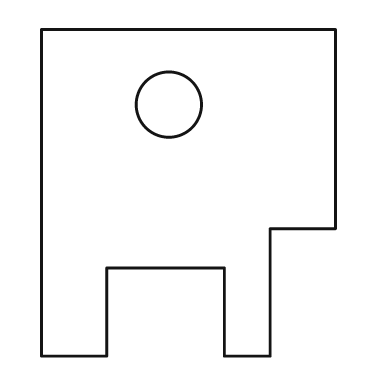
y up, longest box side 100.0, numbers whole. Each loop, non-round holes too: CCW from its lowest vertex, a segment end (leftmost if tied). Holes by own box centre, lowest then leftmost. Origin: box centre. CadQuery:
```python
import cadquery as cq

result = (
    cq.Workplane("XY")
    .moveTo(-45.0, -50.0)
    .lineTo(-25.0, -50.0)
    .lineTo(-25.0, -23.0)
    .lineTo(11.0, -23.0)
    .lineTo(11.0, -50.0)
    .lineTo(25.0, -50.0)
    .lineTo(25.0, -11.0)
    .lineTo(45.0, -11.0)
    .lineTo(45.0, 50.0)
    .lineTo(-45.0, 50.0)
    .close()
    .moveTo(-6.0, 27.0)
    .circle(10.0)
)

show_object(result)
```